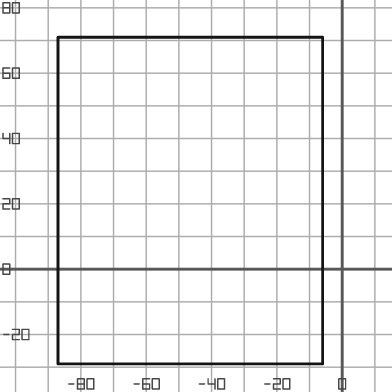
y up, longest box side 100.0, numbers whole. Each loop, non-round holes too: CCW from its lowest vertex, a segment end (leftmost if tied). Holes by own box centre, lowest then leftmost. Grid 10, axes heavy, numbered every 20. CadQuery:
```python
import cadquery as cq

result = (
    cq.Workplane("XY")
    .moveTo(-87.0, -29.0)
    .lineTo(-6.0, -29.0)
    .lineTo(-6.0, 71.0)
    .lineTo(-87.0, 71.0)
    .close()
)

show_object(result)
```